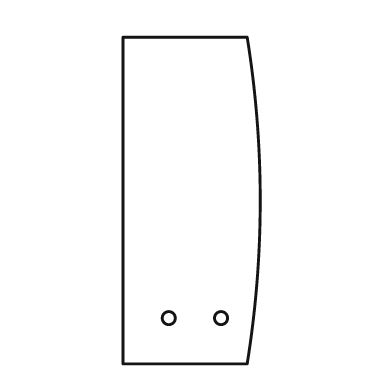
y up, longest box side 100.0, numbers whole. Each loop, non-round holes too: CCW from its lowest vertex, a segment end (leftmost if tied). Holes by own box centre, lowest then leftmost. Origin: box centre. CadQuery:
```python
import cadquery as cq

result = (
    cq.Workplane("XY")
    .moveTo(-21.0, -50.0)
    .lineTo(17.0, -50.0)
    .threePointArc((21.0, 0.0), (17.0, 50.0))
    .lineTo(-21.0, 50.0)
    .close()
    .moveTo(-7.0, -36.0)
    .circle(2.0)
    .moveTo(9.0, -36.0)
    .circle(2.0)
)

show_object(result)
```